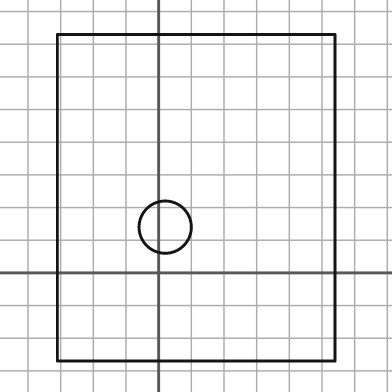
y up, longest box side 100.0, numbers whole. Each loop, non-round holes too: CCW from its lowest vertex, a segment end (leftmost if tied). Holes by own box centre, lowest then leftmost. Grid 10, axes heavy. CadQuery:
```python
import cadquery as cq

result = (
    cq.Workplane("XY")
    .moveTo(-31.0, -27.0)
    .lineTo(54.0, -27.0)
    .lineTo(54.0, 73.0)
    .lineTo(-31.0, 73.0)
    .close()
    .moveTo(2.0, 14.0)
    .circle(8.0)
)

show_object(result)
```